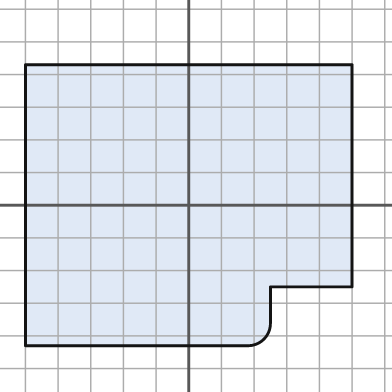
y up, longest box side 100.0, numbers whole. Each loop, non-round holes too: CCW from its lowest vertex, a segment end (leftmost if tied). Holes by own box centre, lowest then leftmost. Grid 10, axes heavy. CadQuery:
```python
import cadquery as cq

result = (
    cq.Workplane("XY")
    .moveTo(-50.0, -43.0)
    .lineTo(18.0, -43.0)
    .threePointArc((23.0, -41.0), (25.0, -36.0))
    .lineTo(25.0, -25.0)
    .lineTo(50.0, -25.0)
    .lineTo(50.0, 43.0)
    .lineTo(-50.0, 43.0)
    .close()
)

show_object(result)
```